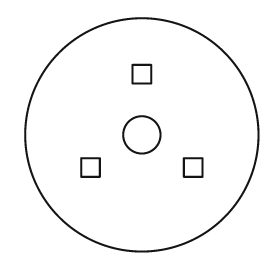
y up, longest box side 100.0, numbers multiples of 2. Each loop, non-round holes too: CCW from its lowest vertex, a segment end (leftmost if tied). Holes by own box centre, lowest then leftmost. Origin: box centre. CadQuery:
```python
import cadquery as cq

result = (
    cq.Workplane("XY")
    .moveTo(0.0, 0.0)
    .circle(50.0)
    .moveTo(-26.0, -18.0)
    .lineTo(-18.0, -18.0)
    .lineTo(-18.0, -10.0)
    .lineTo(-26.0, -10.0)
    .close()
    .moveTo(18.0, -18.0)
    .lineTo(26.0, -18.0)
    .lineTo(26.0, -10.0)
    .lineTo(18.0, -10.0)
    .close()
    .moveTo(0.0, 0.0)
    .circle(8.0)
    .moveTo(-4.0, 22.0)
    .lineTo(4.0, 22.0)
    .lineTo(4.0, 30.0)
    .lineTo(-4.0, 30.0)
    .close()
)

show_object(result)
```